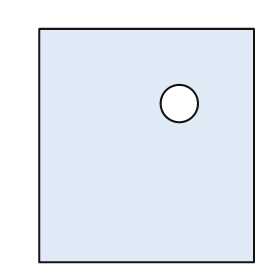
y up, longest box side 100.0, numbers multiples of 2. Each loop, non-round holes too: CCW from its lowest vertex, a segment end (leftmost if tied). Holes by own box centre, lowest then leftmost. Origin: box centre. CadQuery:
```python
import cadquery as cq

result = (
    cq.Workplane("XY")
    .moveTo(-46.0, -50.0)
    .lineTo(46.0, -50.0)
    .lineTo(46.0, 50.0)
    .lineTo(-46.0, 50.0)
    .close()
    .moveTo(14.0, 18.0)
    .circle(8.0)
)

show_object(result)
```